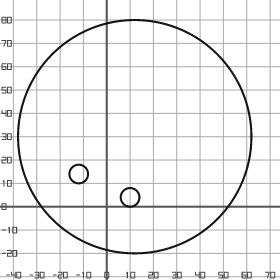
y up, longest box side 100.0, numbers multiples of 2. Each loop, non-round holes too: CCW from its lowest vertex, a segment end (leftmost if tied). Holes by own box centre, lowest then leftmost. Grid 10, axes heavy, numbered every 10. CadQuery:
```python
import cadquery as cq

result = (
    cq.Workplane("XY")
    .moveTo(12.0, 30.0)
    .circle(50.0)
    .moveTo(10.0, 4.0)
    .circle(4.0)
    .moveTo(-12.0, 14.0)
    .circle(4.0)
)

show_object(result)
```